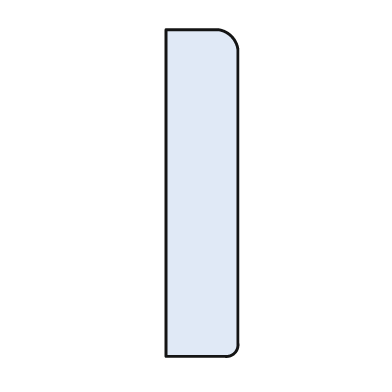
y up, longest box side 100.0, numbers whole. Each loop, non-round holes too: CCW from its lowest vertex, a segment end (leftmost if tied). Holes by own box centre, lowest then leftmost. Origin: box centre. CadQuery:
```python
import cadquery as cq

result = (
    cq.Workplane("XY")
    .moveTo(-11.0, -50.0)
    .lineTo(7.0, -50.0)
    .threePointArc((10.0, -49.0), (11.0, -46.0))
    .lineTo(11.0, 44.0)
    .threePointArc((9.0, 48.0), (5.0, 50.0))
    .lineTo(-11.0, 50.0)
    .close()
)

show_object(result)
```